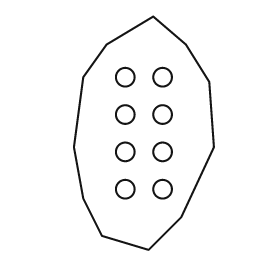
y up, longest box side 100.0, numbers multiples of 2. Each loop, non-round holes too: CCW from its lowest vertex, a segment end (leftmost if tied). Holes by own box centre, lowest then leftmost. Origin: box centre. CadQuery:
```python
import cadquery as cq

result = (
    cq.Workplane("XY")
    .moveTo(2.0, -50.0)
    .lineTo(16.0, -36.0)
    .lineTo(30.0, -6.0)
    .lineTo(28.0, 22.0)
    .lineTo(18.0, 38.0)
    .lineTo(4.0, 50.0)
    .lineTo(-16.0, 38.0)
    .lineTo(-26.0, 24.0)
    .lineTo(-30.0, -6.0)
    .lineTo(-26.0, -28.0)
    .lineTo(-18.0, -44.0)
    .close()
    .moveTo(-8.0, -24.0)
    .circle(4.0)
    .moveTo(8.0, -24.0)
    .circle(4.0)
    .moveTo(-8.0, -8.0)
    .circle(4.0)
    .moveTo(8.0, -8.0)
    .circle(4.0)
    .moveTo(-8.0, 8.0)
    .circle(4.0)
    .moveTo(8.0, 8.0)
    .circle(4.0)
    .moveTo(-8.0, 24.0)
    .circle(4.0)
    .moveTo(8.0, 24.0)
    .circle(4.0)
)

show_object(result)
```